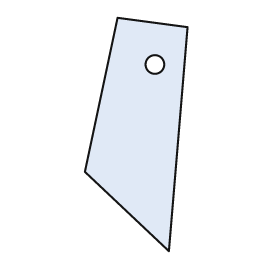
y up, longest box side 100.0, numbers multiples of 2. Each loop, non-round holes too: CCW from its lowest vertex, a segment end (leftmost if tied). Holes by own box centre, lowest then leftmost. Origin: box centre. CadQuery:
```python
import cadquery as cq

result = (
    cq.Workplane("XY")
    .moveTo(14.0, -50.0)
    .lineTo(22.0, 46.0)
    .lineTo(-8.0, 50.0)
    .lineTo(-22.0, -16.0)
    .close()
    .moveTo(8.0, 30.0)
    .circle(4.0)
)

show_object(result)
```